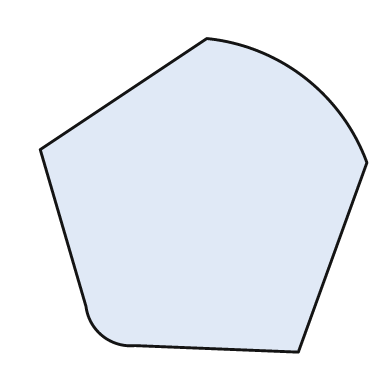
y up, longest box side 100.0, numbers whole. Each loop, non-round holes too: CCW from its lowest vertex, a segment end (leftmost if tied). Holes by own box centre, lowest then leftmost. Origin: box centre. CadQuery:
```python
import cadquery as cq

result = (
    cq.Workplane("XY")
    .moveTo(29.0, -48.0)
    .lineTo(50.0, 10.0)
    .threePointArc((31.0, 36.0), (1.0, 48.0))
    .lineTo(-50.0, 14.0)
    .lineTo(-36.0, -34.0)
    .threePointArc((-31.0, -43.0), (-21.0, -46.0))
    .close()
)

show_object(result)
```